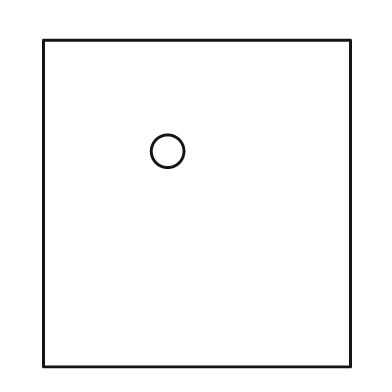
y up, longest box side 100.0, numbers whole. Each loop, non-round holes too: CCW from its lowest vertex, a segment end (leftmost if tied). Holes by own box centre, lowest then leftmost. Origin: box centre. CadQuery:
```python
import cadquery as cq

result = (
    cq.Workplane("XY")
    .moveTo(-47.0, -50.0)
    .lineTo(47.0, -50.0)
    .lineTo(47.0, 50.0)
    .lineTo(-47.0, 50.0)
    .close()
    .moveTo(-9.0, 16.0)
    .circle(5.0)
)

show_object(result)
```